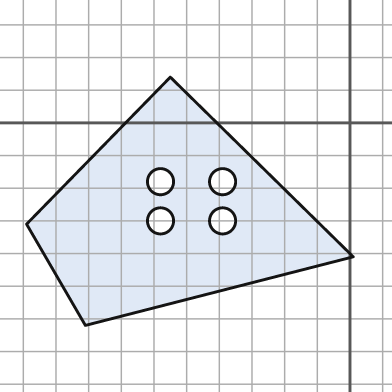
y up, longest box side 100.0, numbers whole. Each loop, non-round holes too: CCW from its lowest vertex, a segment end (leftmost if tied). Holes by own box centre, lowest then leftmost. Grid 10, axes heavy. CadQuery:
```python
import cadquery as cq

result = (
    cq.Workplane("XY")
    .moveTo(-81.0, -62.0)
    .lineTo(1.0, -41.0)
    .lineTo(-55.0, 14.0)
    .lineTo(-99.0, -31.0)
    .close()
    .moveTo(-58.0, -30.0)
    .circle(4.0)
    .moveTo(-39.0, -30.0)
    .circle(4.0)
    .moveTo(-58.0, -18.0)
    .circle(4.0)
    .moveTo(-39.0, -18.0)
    .circle(4.0)
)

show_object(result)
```